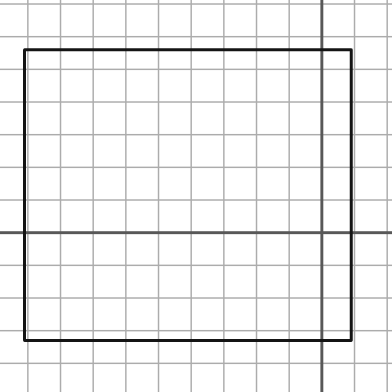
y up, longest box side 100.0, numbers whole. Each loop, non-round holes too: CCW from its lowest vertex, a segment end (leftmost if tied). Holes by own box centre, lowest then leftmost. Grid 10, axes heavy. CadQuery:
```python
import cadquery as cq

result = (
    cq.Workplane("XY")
    .moveTo(-91.0, -33.0)
    .lineTo(9.0, -33.0)
    .lineTo(9.0, 56.0)
    .lineTo(-91.0, 56.0)
    .close()
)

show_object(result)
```